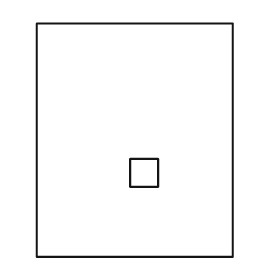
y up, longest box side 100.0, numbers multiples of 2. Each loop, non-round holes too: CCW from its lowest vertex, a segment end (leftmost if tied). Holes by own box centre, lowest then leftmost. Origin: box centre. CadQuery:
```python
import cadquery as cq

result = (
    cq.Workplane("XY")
    .moveTo(-42.0, -50.0)
    .lineTo(42.0, -50.0)
    .lineTo(42.0, 50.0)
    .lineTo(-42.0, 50.0)
    .close()
    .moveTo(-2.0, -20.0)
    .lineTo(10.0, -20.0)
    .lineTo(10.0, -8.0)
    .lineTo(-2.0, -8.0)
    .close()
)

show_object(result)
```